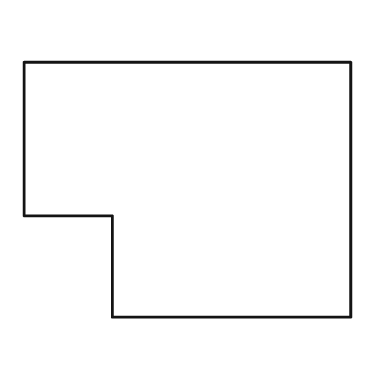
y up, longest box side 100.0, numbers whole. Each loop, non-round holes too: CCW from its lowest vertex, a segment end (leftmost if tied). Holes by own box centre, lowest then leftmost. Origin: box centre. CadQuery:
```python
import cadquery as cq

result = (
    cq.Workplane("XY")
    .moveTo(-23.0, -39.0)
    .lineTo(50.0, -39.0)
    .lineTo(50.0, 39.0)
    .lineTo(-50.0, 39.0)
    .lineTo(-50.0, -8.0)
    .lineTo(-23.0, -8.0)
    .close()
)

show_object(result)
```